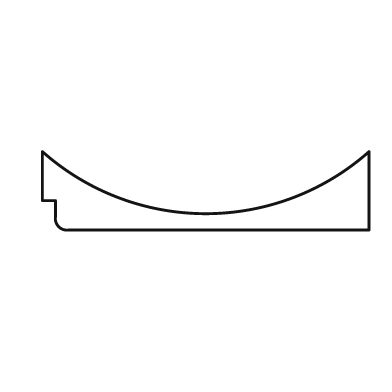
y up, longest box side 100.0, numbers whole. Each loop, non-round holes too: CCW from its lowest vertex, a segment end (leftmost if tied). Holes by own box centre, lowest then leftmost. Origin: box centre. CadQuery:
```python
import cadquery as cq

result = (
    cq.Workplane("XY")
    .moveTo(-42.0, -12.0)
    .lineTo(50.0, -12.0)
    .lineTo(50.0, 12.0)
    .threePointArc((0.0, -7.0), (-50.0, 12.0))
    .lineTo(-50.0, -3.0)
    .lineTo(-46.0, -3.0)
    .lineTo(-46.0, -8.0)
    .threePointArc((-45.0, -11.0), (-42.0, -12.0))
    .close()
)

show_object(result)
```